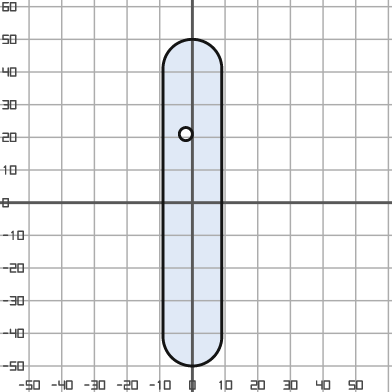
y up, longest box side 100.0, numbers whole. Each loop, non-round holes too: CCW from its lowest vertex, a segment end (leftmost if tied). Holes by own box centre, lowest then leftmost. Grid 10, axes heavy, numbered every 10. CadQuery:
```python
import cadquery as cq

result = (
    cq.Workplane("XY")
    .moveTo(-9.0, -41.0)
    .threePointArc((0.0, -50.0), (9.0, -41.0))
    .lineTo(9.0, 41.0)
    .threePointArc((0.0, 50.0), (-9.0, 41.0))
    .close()
    .moveTo(-2.0, 21.0)
    .circle(2.0)
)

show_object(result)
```